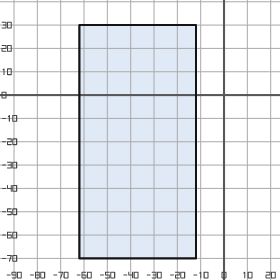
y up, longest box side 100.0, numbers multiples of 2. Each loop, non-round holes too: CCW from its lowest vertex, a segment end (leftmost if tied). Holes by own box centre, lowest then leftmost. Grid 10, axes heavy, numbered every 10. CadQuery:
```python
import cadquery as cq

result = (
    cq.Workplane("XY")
    .moveTo(-62.0, -70.0)
    .lineTo(-12.0, -70.0)
    .lineTo(-12.0, 30.0)
    .lineTo(-62.0, 30.0)
    .close()
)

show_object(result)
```